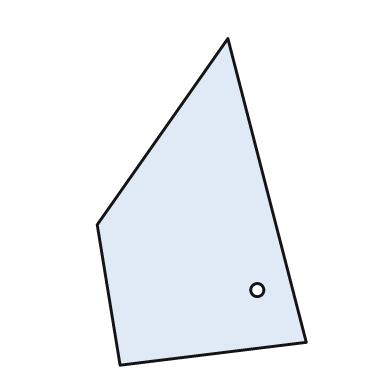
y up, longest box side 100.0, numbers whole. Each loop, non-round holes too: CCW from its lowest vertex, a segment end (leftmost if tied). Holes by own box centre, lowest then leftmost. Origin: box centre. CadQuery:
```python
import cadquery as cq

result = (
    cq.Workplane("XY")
    .moveTo(-25.0, -50.0)
    .lineTo(32.0, -43.0)
    .lineTo(8.0, 50.0)
    .lineTo(-32.0, -7.0)
    .close()
    .moveTo(17.0, -27.0)
    .circle(2.0)
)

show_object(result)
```